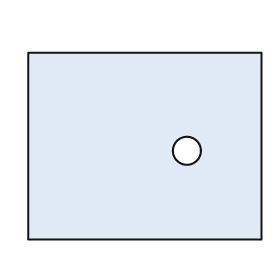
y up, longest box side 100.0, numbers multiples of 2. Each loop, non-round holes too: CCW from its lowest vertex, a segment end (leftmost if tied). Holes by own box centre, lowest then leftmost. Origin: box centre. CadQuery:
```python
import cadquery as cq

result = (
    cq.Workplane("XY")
    .moveTo(-50.0, -40.0)
    .lineTo(50.0, -40.0)
    .lineTo(50.0, 40.0)
    .lineTo(-50.0, 40.0)
    .close()
    .moveTo(18.0, -2.0)
    .circle(6.0)
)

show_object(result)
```